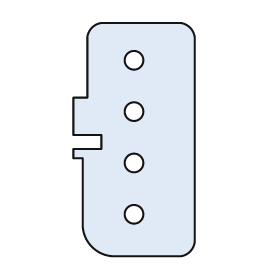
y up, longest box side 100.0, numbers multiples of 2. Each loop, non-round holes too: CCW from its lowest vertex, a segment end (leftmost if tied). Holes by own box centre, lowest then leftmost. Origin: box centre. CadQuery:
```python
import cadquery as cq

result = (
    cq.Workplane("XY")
    .moveTo(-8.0, -50.0)
    .lineTo(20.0, -50.0)
    .threePointArc((24.0, -48.0), (26.0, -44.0))
    .lineTo(26.0, 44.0)
    .threePointArc((24.0, 48.0), (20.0, 50.0))
    .lineTo(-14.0, 50.0)
    .threePointArc((-18.0, 48.0), (-20.0, 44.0))
    .lineTo(-20.0, 18.0)
    .lineTo(-26.0, 18.0)
    .lineTo(-26.0, 2.0)
    .lineTo(-14.0, 2.0)
    .lineTo(-14.0, -4.0)
    .lineTo(-26.0, -4.0)
    .lineTo(-26.0, -8.0)
    .lineTo(-22.0, -8.0)
    .lineTo(-22.0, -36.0)
    .threePointArc((-18.0, -46.0), (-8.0, -50.0))
    .close()
    .moveTo(0.0, -32.0)
    .circle(4.0)
    .moveTo(0.0, -10.0)
    .circle(4.0)
    .moveTo(0.0, 12.0)
    .circle(4.0)
    .moveTo(0.0, 34.0)
    .circle(4.0)
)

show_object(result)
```